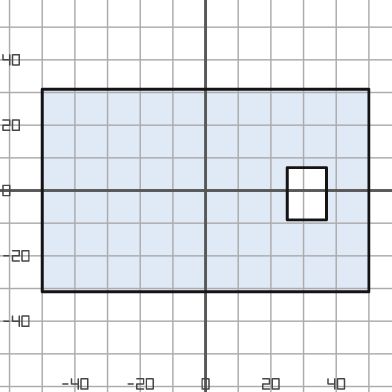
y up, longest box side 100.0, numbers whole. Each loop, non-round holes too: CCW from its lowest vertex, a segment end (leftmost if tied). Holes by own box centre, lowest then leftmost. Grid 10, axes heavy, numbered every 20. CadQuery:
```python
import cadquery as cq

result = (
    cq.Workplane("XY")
    .moveTo(-50.0, -31.0)
    .lineTo(50.0, -31.0)
    .lineTo(50.0, 31.0)
    .lineTo(-50.0, 31.0)
    .close()
    .moveTo(25.0, -9.0)
    .lineTo(37.0, -9.0)
    .lineTo(37.0, 7.0)
    .lineTo(25.0, 7.0)
    .close()
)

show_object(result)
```